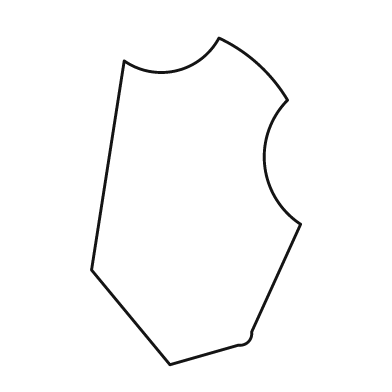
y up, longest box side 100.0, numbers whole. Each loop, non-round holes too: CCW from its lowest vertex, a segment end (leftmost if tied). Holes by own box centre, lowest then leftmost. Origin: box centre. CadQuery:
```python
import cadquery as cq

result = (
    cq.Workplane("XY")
    .moveTo(-8.0, -50.0)
    .lineTo(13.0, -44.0)
    .threePointArc((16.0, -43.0), (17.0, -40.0))
    .lineTo(32.0, -7.0)
    .threePointArc((21.0, 11.0), (28.0, 31.0))
    .threePointArc((19.0, 42.0), (7.0, 50.0))
    .threePointArc((-6.0, 40.0), (-22.0, 43.0))
    .lineTo(-32.0, -21.0)
    .close()
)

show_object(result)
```